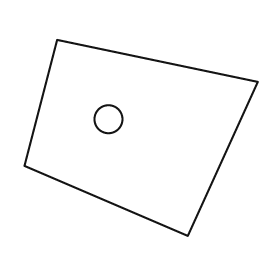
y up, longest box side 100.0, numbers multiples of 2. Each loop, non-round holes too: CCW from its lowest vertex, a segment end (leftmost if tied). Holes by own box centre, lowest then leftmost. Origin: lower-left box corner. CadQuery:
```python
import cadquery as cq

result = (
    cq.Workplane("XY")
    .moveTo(70.0, 0.0)
    .lineTo(100.0, 66.0)
    .lineTo(14.0, 84.0)
    .lineTo(0.0, 30.0)
    .close()
    .moveTo(36.0, 50.0)
    .circle(6.0)
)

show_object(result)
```